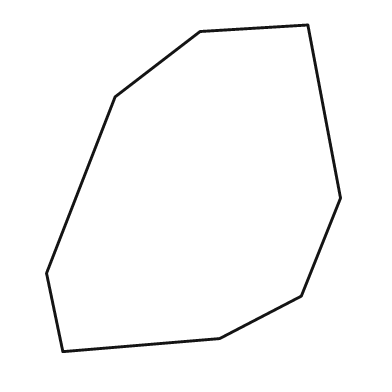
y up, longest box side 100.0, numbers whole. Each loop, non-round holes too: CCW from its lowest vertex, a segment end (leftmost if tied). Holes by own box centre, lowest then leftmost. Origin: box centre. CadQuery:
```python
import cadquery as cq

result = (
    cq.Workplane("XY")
    .moveTo(-40.0, -50.0)
    .lineTo(8.0, -46.0)
    .lineTo(33.0, -33.0)
    .lineTo(45.0, -3.0)
    .lineTo(35.0, 50.0)
    .lineTo(2.0, 48.0)
    .lineTo(-24.0, 28.0)
    .lineTo(-45.0, -26.0)
    .close()
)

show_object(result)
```